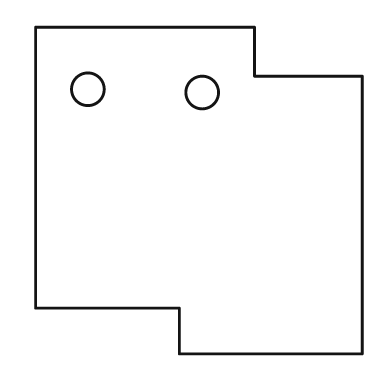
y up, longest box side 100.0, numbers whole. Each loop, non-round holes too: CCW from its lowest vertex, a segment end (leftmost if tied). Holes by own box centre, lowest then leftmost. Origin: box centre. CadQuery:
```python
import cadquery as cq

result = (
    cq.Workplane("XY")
    .moveTo(-6.0, -50.0)
    .lineTo(50.0, -50.0)
    .lineTo(50.0, 35.0)
    .lineTo(17.0, 35.0)
    .lineTo(17.0, 50.0)
    .lineTo(-50.0, 50.0)
    .lineTo(-50.0, -36.0)
    .lineTo(-6.0, -36.0)
    .close()
    .moveTo(1.0, 30.0)
    .circle(5.0)
    .moveTo(-34.0, 31.0)
    .circle(5.0)
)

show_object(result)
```